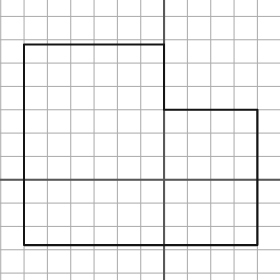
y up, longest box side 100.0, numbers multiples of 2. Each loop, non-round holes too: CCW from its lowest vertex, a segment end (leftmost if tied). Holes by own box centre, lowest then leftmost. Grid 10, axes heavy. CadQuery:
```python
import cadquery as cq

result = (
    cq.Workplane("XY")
    .moveTo(-60.0, -28.0)
    .lineTo(40.0, -28.0)
    .lineTo(40.0, 30.0)
    .lineTo(0.0, 30.0)
    .lineTo(0.0, 58.0)
    .lineTo(-60.0, 58.0)
    .close()
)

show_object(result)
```